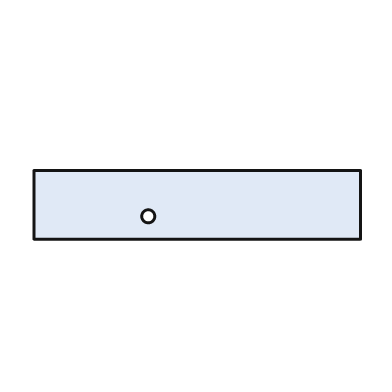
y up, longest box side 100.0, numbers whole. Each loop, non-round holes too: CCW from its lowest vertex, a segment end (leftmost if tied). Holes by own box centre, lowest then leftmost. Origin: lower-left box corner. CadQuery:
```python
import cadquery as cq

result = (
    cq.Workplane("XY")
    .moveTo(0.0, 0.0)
    .lineTo(100.0, 0.0)
    .lineTo(100.0, 21.0)
    .lineTo(0.0, 21.0)
    .close()
    .moveTo(35.0, 7.0)
    .circle(2.0)
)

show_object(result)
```